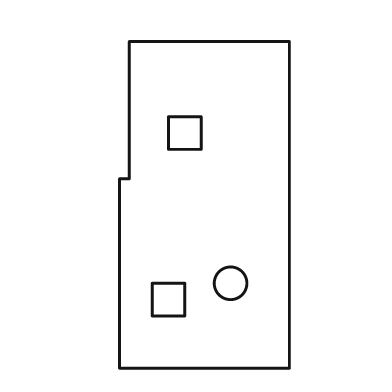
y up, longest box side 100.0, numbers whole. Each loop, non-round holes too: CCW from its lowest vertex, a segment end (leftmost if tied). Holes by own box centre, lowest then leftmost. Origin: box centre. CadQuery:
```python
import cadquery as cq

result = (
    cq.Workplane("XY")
    .moveTo(-26.0, -50.0)
    .lineTo(26.0, -50.0)
    .lineTo(26.0, 50.0)
    .lineTo(-23.0, 50.0)
    .lineTo(-23.0, 8.0)
    .lineTo(-26.0, 8.0)
    .close()
    .moveTo(-16.0, -34.0)
    .lineTo(-6.0, -34.0)
    .lineTo(-6.0, -24.0)
    .lineTo(-16.0, -24.0)
    .close()
    .moveTo(8.0, -24.0)
    .circle(5.0)
    .moveTo(-11.0, 17.0)
    .lineTo(-1.0, 17.0)
    .lineTo(-1.0, 27.0)
    .lineTo(-11.0, 27.0)
    .close()
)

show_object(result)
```